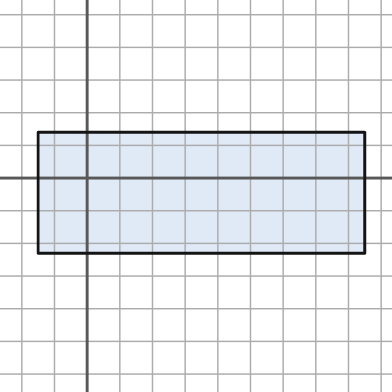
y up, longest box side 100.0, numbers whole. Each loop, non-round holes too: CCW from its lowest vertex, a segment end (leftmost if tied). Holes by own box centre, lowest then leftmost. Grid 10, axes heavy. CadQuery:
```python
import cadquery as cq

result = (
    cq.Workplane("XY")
    .moveTo(-15.0, -23.0)
    .lineTo(85.0, -23.0)
    .lineTo(85.0, 14.0)
    .lineTo(-15.0, 14.0)
    .close()
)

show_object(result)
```